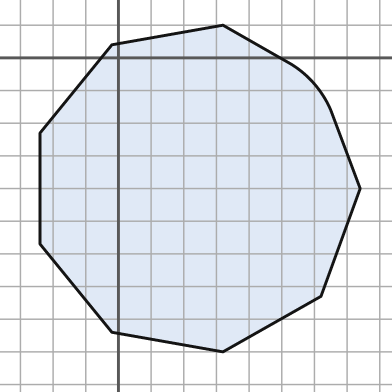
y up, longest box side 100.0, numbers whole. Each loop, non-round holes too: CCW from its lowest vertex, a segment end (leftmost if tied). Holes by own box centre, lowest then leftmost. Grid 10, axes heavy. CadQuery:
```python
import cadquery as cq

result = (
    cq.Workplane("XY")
    .moveTo(32.0, -90.0)
    .lineTo(62.0, -73.0)
    .lineTo(74.0, -40.0)
    .lineTo(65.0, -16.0)
    .threePointArc((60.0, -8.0), (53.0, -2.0))
    .lineTo(32.0, 10.0)
    .lineTo(-2.0, 4.0)
    .lineTo(-24.0, -23.0)
    .lineTo(-24.0, -57.0)
    .lineTo(-2.0, -84.0)
    .close()
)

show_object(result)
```